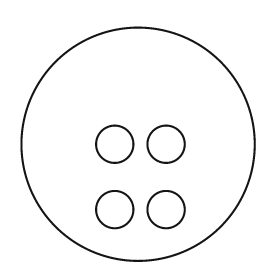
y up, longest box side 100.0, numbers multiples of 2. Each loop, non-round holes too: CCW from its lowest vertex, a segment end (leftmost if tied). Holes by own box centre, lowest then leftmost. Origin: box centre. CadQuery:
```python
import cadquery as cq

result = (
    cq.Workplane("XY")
    .moveTo(0.0, 0.0)
    .circle(50.0)
    .moveTo(-10.0, -28.0)
    .circle(8.0)
    .moveTo(12.0, -28.0)
    .circle(8.0)
    .moveTo(-10.0, 0.0)
    .circle(8.0)
    .moveTo(12.0, 0.0)
    .circle(8.0)
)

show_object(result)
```